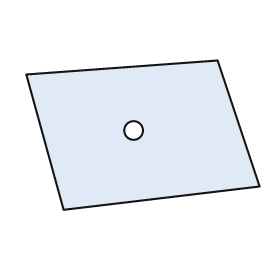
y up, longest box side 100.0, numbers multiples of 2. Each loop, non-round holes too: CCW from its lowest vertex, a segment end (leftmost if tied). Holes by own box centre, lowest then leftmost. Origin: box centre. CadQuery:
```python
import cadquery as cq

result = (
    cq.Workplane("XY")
    .moveTo(-34.0, -32.0)
    .lineTo(50.0, -22.0)
    .lineTo(32.0, 32.0)
    .lineTo(-50.0, 26.0)
    .close()
    .moveTo(-4.0, 2.0)
    .circle(4.0)
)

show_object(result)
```